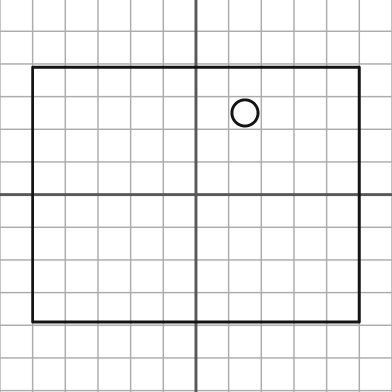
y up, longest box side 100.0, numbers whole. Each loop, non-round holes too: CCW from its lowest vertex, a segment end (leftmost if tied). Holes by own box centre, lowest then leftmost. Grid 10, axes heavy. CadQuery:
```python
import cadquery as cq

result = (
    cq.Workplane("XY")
    .moveTo(-50.0, -39.0)
    .lineTo(50.0, -39.0)
    .lineTo(50.0, 39.0)
    .lineTo(-50.0, 39.0)
    .close()
    .moveTo(15.0, 25.0)
    .circle(4.0)
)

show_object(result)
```